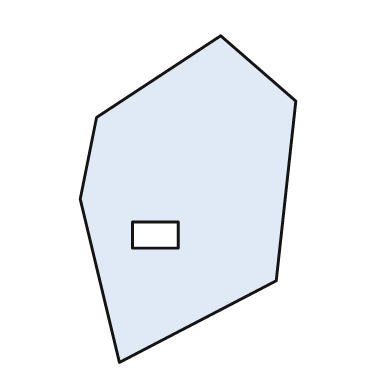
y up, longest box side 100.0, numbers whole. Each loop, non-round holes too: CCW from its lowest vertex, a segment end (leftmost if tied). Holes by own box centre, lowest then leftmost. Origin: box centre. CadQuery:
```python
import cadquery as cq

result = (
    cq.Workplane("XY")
    .moveTo(-21.0, -50.0)
    .lineTo(27.0, -25.0)
    .lineTo(33.0, 30.0)
    .lineTo(10.0, 50.0)
    .lineTo(-28.0, 25.0)
    .lineTo(-33.0, 0.0)
    .close()
    .moveTo(-17.0, -15.0)
    .lineTo(-3.0, -15.0)
    .lineTo(-3.0, -7.0)
    .lineTo(-17.0, -7.0)
    .close()
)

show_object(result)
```